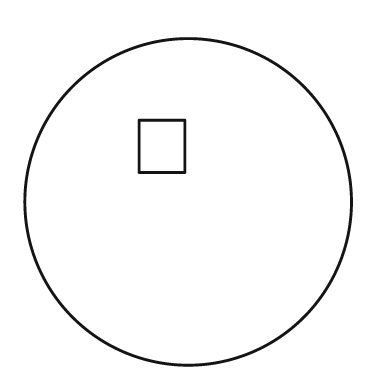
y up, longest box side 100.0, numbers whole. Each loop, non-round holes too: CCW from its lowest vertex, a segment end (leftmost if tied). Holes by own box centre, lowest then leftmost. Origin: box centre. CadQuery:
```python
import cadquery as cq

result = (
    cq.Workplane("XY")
    .moveTo(0.0, 0.0)
    .circle(50.0)
    .moveTo(-15.0, 9.0)
    .lineTo(-1.0, 9.0)
    .lineTo(-1.0, 25.0)
    .lineTo(-15.0, 25.0)
    .close()
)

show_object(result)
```